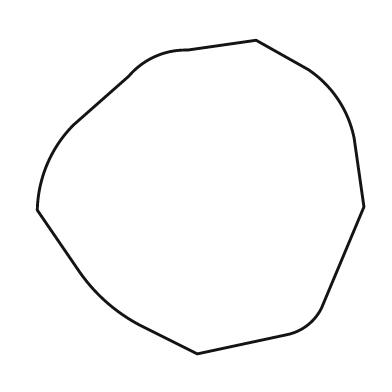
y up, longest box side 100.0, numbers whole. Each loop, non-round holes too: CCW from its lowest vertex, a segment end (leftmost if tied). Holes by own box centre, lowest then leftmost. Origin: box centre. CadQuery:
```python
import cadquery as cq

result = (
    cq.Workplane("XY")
    .moveTo(-1.0, -48.0)
    .lineTo(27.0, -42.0)
    .threePointArc((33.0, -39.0), (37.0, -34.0))
    .lineTo(50.0, -3.0)
    .lineTo(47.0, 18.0)
    .threePointArc((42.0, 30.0), (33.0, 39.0))
    .lineTo(17.0, 48.0)
    .lineTo(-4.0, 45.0)
    .threePointArc((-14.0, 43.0), (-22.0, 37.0))
    .lineTo(-39.0, 22.0)
    .threePointArc((-47.0, 10.0), (-50.0, -4.0))
    .lineTo(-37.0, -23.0)
    .threePointArc((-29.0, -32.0), (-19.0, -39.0))
    .close()
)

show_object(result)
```